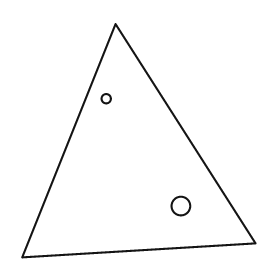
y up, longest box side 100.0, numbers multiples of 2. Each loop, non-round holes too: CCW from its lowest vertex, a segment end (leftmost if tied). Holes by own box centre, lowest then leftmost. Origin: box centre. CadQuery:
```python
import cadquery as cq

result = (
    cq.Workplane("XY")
    .moveTo(-50.0, -50.0)
    .lineTo(50.0, -44.0)
    .lineTo(-10.0, 50.0)
    .close()
    .moveTo(18.0, -28.0)
    .circle(4.0)
    .moveTo(-14.0, 18.0)
    .circle(2.0)
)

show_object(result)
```